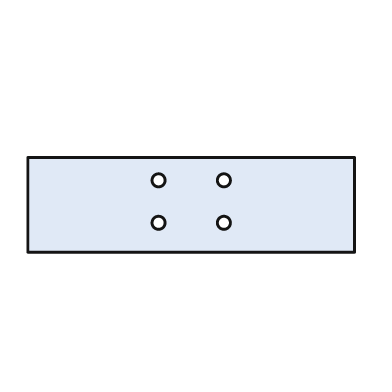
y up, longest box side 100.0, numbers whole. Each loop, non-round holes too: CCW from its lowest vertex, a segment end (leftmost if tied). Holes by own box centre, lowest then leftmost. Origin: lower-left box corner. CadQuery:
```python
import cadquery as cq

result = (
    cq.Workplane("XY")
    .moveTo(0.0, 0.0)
    .lineTo(100.0, 0.0)
    .lineTo(100.0, 29.0)
    .lineTo(0.0, 29.0)
    .close()
    .moveTo(40.0, 9.0)
    .circle(2.0)
    .moveTo(60.0, 9.0)
    .circle(2.0)
    .moveTo(40.0, 22.0)
    .circle(2.0)
    .moveTo(60.0, 22.0)
    .circle(2.0)
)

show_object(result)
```